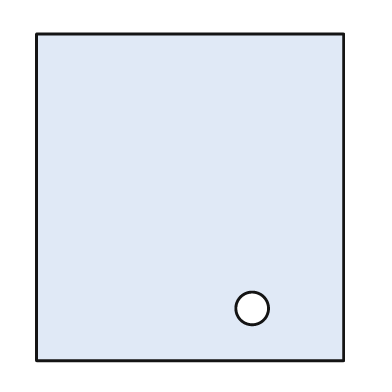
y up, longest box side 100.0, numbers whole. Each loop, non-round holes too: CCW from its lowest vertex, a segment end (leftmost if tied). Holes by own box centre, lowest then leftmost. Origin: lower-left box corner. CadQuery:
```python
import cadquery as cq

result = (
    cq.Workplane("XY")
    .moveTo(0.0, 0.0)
    .lineTo(94.0, 0.0)
    .lineTo(94.0, 100.0)
    .lineTo(0.0, 100.0)
    .close()
    .moveTo(66.0, 16.0)
    .circle(5.0)
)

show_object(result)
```